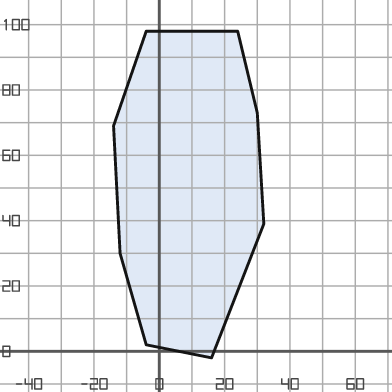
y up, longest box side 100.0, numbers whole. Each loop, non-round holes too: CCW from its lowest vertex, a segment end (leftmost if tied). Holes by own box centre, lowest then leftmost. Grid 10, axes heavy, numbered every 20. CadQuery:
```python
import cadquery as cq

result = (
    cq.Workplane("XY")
    .moveTo(16.0, -2.0)
    .lineTo(32.0, 39.0)
    .lineTo(30.0, 73.0)
    .lineTo(24.0, 98.0)
    .lineTo(-4.0, 98.0)
    .lineTo(-14.0, 69.0)
    .lineTo(-12.0, 30.0)
    .lineTo(-4.0, 2.0)
    .close()
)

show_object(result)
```